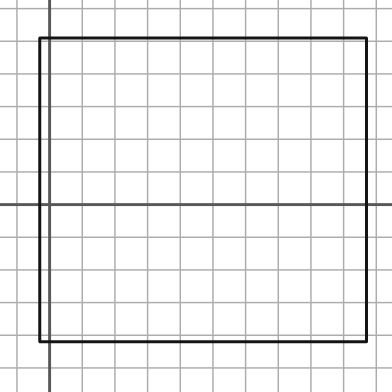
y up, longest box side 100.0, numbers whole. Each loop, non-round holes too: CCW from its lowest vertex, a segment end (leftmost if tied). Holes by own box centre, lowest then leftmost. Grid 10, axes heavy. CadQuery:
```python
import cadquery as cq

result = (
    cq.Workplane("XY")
    .moveTo(-3.0, -42.0)
    .lineTo(97.0, -42.0)
    .lineTo(97.0, 51.0)
    .lineTo(-3.0, 51.0)
    .close()
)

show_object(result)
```